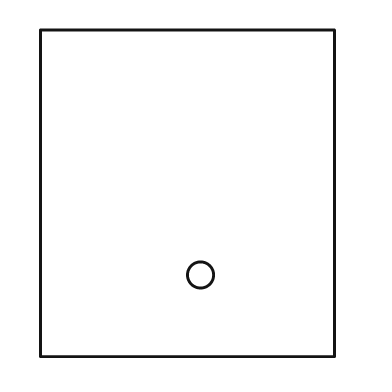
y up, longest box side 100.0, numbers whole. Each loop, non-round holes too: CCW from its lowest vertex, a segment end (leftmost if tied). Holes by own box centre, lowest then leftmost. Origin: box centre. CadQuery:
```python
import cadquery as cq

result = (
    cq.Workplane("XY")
    .moveTo(-45.0, -50.0)
    .lineTo(45.0, -50.0)
    .lineTo(45.0, 50.0)
    .lineTo(-45.0, 50.0)
    .close()
    .moveTo(4.0, -25.0)
    .circle(4.0)
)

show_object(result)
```